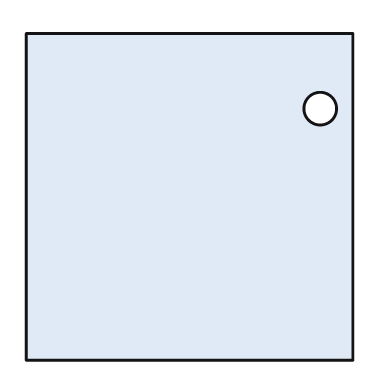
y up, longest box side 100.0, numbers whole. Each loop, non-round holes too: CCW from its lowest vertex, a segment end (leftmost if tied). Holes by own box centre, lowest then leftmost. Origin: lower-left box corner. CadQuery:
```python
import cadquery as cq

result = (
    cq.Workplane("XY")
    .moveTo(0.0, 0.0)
    .lineTo(100.0, 0.0)
    .lineTo(100.0, 100.0)
    .lineTo(0.0, 100.0)
    .close()
    .moveTo(90.0, 77.0)
    .circle(5.0)
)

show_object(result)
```